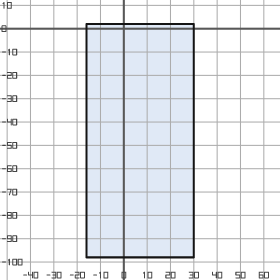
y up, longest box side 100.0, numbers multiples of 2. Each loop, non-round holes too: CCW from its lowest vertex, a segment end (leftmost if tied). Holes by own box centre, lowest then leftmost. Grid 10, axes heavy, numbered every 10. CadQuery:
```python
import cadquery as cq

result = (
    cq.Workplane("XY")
    .moveTo(-16.0, -98.0)
    .lineTo(30.0, -98.0)
    .lineTo(30.0, 2.0)
    .lineTo(-16.0, 2.0)
    .close()
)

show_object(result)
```